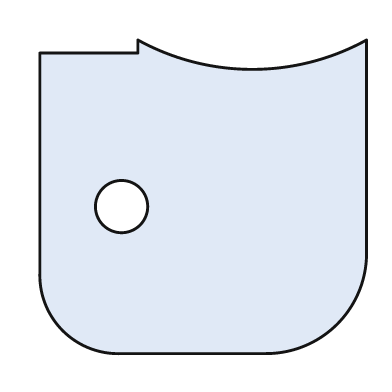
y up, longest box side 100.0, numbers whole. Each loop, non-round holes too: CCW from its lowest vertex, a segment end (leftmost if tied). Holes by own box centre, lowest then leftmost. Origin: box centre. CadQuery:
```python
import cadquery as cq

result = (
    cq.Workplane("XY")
    .moveTo(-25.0, -48.0)
    .lineTo(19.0, -48.0)
    .threePointArc((41.0, -39.0), (50.0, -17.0))
    .lineTo(50.0, 48.0)
    .threePointArc((15.0, 39.0), (-20.0, 48.0))
    .lineTo(-20.0, 44.0)
    .lineTo(-50.0, 44.0)
    .lineTo(-50.0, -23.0)
    .threePointArc((-43.0, -41.0), (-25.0, -48.0))
    .close()
    .moveTo(-25.0, -3.0)
    .circle(8.0)
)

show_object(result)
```